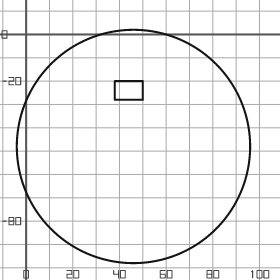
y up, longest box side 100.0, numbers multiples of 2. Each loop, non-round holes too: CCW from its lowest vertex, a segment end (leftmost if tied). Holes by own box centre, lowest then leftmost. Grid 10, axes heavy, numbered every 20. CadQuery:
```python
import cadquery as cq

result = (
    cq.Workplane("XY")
    .moveTo(46.0, -48.0)
    .circle(50.0)
    .moveTo(38.0, -28.0)
    .lineTo(50.0, -28.0)
    .lineTo(50.0, -20.0)
    .lineTo(38.0, -20.0)
    .close()
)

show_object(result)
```